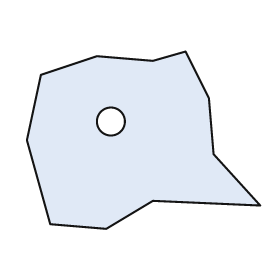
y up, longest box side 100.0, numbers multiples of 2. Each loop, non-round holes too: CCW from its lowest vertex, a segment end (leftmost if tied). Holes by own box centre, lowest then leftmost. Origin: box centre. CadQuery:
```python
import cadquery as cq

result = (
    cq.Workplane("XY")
    .moveTo(-16.0, -38.0)
    .lineTo(4.0, -26.0)
    .lineTo(50.0, -28.0)
    .lineTo(30.0, -6.0)
    .lineTo(28.0, 18.0)
    .lineTo(18.0, 38.0)
    .lineTo(4.0, 34.0)
    .lineTo(-20.0, 36.0)
    .lineTo(-44.0, 28.0)
    .lineTo(-50.0, 0.0)
    .lineTo(-40.0, -36.0)
    .close()
    .moveTo(-14.0, 8.0)
    .circle(6.0)
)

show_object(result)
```